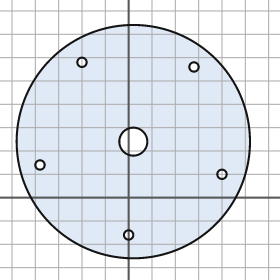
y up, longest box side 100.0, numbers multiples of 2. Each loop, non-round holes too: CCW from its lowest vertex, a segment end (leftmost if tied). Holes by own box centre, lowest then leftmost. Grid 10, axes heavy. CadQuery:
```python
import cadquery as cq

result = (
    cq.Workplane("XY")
    .moveTo(2.0, 24.0)
    .circle(50.0)
    .moveTo(0.0, -16.0)
    .circle(2.0)
    .moveTo(40.0, 10.0)
    .circle(2.0)
    .moveTo(-38.0, 14.0)
    .circle(2.0)
    .moveTo(2.0, 24.0)
    .circle(6.0)
    .moveTo(28.0, 56.0)
    .circle(2.0)
    .moveTo(-20.0, 58.0)
    .circle(2.0)
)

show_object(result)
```